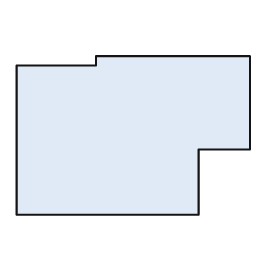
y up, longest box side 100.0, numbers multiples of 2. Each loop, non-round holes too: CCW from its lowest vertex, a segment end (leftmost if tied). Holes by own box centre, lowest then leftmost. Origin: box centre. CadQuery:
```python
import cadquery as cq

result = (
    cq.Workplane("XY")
    .moveTo(-50.0, -34.0)
    .lineTo(28.0, -34.0)
    .lineTo(28.0, -6.0)
    .lineTo(50.0, -6.0)
    .lineTo(50.0, 34.0)
    .lineTo(-16.0, 34.0)
    .lineTo(-16.0, 30.0)
    .lineTo(-50.0, 30.0)
    .close()
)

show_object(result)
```